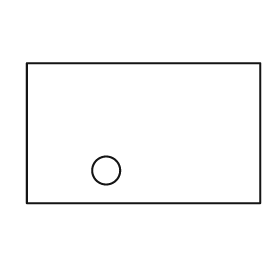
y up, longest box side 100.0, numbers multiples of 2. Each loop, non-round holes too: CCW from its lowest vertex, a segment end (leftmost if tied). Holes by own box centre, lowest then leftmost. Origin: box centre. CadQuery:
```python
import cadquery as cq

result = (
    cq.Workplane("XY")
    .moveTo(-50.0, -30.0)
    .lineTo(50.0, -30.0)
    .lineTo(50.0, 30.0)
    .lineTo(-50.0, 30.0)
    .close()
    .moveTo(-16.0, -16.0)
    .circle(6.0)
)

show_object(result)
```